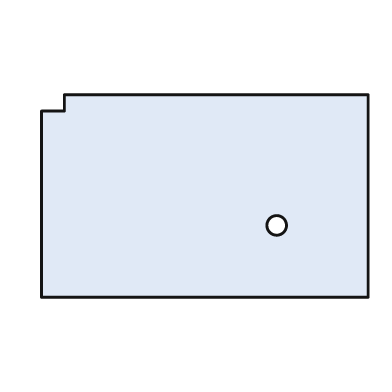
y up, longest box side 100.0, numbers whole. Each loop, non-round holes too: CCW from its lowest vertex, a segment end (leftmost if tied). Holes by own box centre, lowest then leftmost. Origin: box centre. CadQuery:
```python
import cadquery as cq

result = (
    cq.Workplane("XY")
    .moveTo(-50.0, -31.0)
    .lineTo(50.0, -31.0)
    .lineTo(50.0, 31.0)
    .lineTo(-43.0, 31.0)
    .lineTo(-43.0, 26.0)
    .lineTo(-50.0, 26.0)
    .close()
    .moveTo(22.0, -9.0)
    .circle(3.0)
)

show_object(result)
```